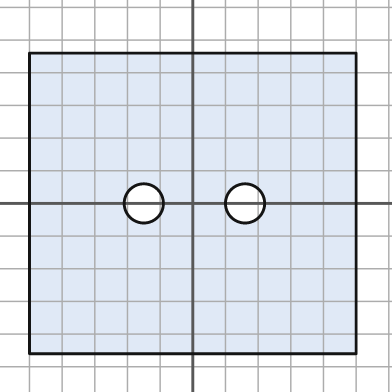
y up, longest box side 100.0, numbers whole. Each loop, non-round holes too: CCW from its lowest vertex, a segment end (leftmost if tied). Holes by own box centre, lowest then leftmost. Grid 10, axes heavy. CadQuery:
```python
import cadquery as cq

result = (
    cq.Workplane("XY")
    .moveTo(-50.0, -46.0)
    .lineTo(50.0, -46.0)
    .lineTo(50.0, 46.0)
    .lineTo(-50.0, 46.0)
    .close()
    .moveTo(-15.0, 0.0)
    .circle(6.0)
    .moveTo(16.0, 0.0)
    .circle(6.0)
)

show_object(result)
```